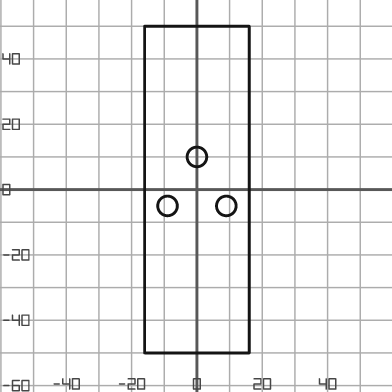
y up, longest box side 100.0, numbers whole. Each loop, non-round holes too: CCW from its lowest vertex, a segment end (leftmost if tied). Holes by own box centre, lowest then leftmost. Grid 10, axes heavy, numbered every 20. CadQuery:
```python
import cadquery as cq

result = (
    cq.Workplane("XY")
    .moveTo(-16.0, -50.0)
    .lineTo(16.0, -50.0)
    .lineTo(16.0, 50.0)
    .lineTo(-16.0, 50.0)
    .close()
    .moveTo(-9.0, -5.0)
    .circle(3.0)
    .moveTo(9.0, -5.0)
    .circle(3.0)
    .moveTo(0.0, 10.0)
    .circle(3.0)
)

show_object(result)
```